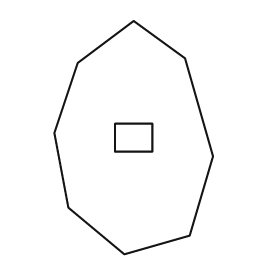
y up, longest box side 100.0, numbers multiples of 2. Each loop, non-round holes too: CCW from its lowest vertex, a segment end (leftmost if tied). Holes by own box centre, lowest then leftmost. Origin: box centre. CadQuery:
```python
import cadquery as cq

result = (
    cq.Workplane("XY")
    .moveTo(-4.0, -50.0)
    .lineTo(24.0, -42.0)
    .lineTo(34.0, -8.0)
    .lineTo(22.0, 34.0)
    .lineTo(0.0, 50.0)
    .lineTo(-24.0, 32.0)
    .lineTo(-34.0, 2.0)
    .lineTo(-28.0, -30.0)
    .close()
    .moveTo(-8.0, -6.0)
    .lineTo(8.0, -6.0)
    .lineTo(8.0, 6.0)
    .lineTo(-8.0, 6.0)
    .close()
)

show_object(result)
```